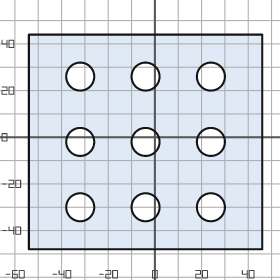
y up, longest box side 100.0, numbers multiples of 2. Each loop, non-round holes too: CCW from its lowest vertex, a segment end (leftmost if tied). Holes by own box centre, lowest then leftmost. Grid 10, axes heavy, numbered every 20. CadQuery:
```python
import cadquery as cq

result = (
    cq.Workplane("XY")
    .moveTo(-54.0, -48.0)
    .lineTo(46.0, -48.0)
    .lineTo(46.0, 44.0)
    .lineTo(-54.0, 44.0)
    .close()
    .moveTo(-32.0, -30.0)
    .circle(6.0)
    .moveTo(-4.0, -30.0)
    .circle(6.0)
    .moveTo(24.0, -30.0)
    .circle(6.0)
    .moveTo(-32.0, -2.0)
    .circle(6.0)
    .moveTo(-4.0, -2.0)
    .circle(6.0)
    .moveTo(24.0, -2.0)
    .circle(6.0)
    .moveTo(-32.0, 26.0)
    .circle(6.0)
    .moveTo(-4.0, 26.0)
    .circle(6.0)
    .moveTo(24.0, 26.0)
    .circle(6.0)
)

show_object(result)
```